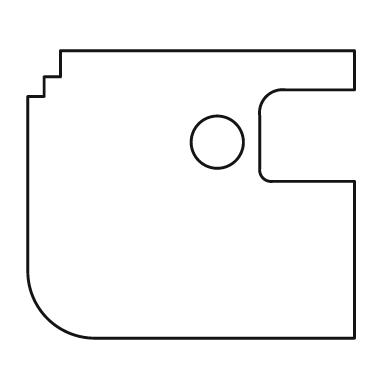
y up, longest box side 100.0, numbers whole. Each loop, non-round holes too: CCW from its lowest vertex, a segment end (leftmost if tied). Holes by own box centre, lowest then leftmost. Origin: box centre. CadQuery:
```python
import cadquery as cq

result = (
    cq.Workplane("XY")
    .moveTo(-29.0, -44.0)
    .lineTo(50.0, -44.0)
    .lineTo(50.0, 4.0)
    .lineTo(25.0, 4.0)
    .threePointArc((22.0, 5.0), (21.0, 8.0))
    .lineTo(21.0, 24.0)
    .threePointArc((23.0, 30.0), (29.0, 32.0))
    .lineTo(50.0, 32.0)
    .lineTo(50.0, 44.0)
    .lineTo(-40.0, 44.0)
    .lineTo(-40.0, 36.0)
    .lineTo(-45.0, 36.0)
    .lineTo(-45.0, 30.0)
    .lineTo(-50.0, 30.0)
    .lineTo(-50.0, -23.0)
    .threePointArc((-44.0, -38.0), (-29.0, -44.0))
    .close()
    .moveTo(8.0, 16.0)
    .circle(8.0)
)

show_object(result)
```